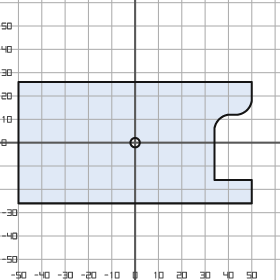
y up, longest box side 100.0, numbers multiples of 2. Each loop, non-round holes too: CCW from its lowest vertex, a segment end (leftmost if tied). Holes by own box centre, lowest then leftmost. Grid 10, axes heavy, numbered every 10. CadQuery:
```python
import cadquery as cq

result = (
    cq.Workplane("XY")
    .moveTo(-50.0, -26.0)
    .lineTo(50.0, -26.0)
    .lineTo(50.0, -16.0)
    .lineTo(34.0, -16.0)
    .lineTo(34.0, 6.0)
    .threePointArc((36.0, 10.0), (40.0, 12.0))
    .lineTo(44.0, 12.0)
    .threePointArc((48.0, 14.0), (50.0, 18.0))
    .lineTo(50.0, 26.0)
    .lineTo(-50.0, 26.0)
    .close()
    .moveTo(0.0, 0.0)
    .circle(2.0)
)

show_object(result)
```